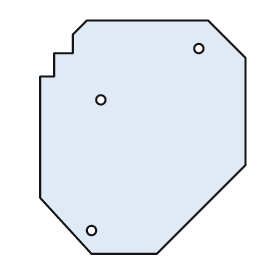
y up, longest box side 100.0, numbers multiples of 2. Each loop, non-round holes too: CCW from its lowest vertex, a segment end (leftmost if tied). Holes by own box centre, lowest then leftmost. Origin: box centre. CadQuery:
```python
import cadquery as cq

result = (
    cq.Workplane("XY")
    .moveTo(-22.0, -50.0)
    .lineTo(6.0, -50.0)
    .lineTo(44.0, -12.0)
    .lineTo(44.0, 34.0)
    .lineTo(28.0, 50.0)
    .lineTo(-24.0, 50.0)
    .lineTo(-30.0, 44.0)
    .lineTo(-30.0, 36.0)
    .lineTo(-38.0, 36.0)
    .lineTo(-38.0, 26.0)
    .lineTo(-44.0, 26.0)
    .lineTo(-44.0, -26.0)
    .close()
    .moveTo(-22.0, -40.0)
    .circle(2.0)
    .moveTo(-18.0, 16.0)
    .circle(2.0)
    .moveTo(24.0, 38.0)
    .circle(2.0)
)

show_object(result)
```